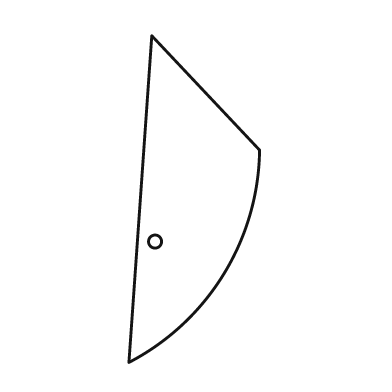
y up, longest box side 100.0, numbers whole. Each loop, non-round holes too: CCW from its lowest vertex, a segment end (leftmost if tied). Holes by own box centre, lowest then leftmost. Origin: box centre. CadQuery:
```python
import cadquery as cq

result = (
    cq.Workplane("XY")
    .moveTo(-20.0, -50.0)
    .threePointArc((9.0, -23.0), (20.0, 15.0))
    .lineTo(-13.0, 50.0)
    .close()
    .moveTo(-12.0, -13.0)
    .circle(2.0)
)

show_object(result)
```